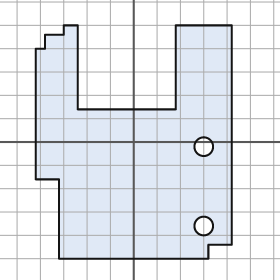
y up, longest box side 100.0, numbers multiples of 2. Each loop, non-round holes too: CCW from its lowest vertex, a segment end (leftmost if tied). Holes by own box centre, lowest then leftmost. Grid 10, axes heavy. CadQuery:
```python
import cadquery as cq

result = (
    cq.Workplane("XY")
    .moveTo(-32.0, -50.0)
    .lineTo(32.0, -50.0)
    .lineTo(32.0, -44.0)
    .lineTo(42.0, -44.0)
    .lineTo(42.0, 50.0)
    .lineTo(18.0, 50.0)
    .lineTo(18.0, 14.0)
    .lineTo(-24.0, 14.0)
    .lineTo(-24.0, 50.0)
    .lineTo(-30.0, 50.0)
    .lineTo(-30.0, 46.0)
    .lineTo(-38.0, 46.0)
    .lineTo(-38.0, 40.0)
    .lineTo(-42.0, 40.0)
    .lineTo(-42.0, -16.0)
    .lineTo(-32.0, -16.0)
    .close()
    .moveTo(30.0, -36.0)
    .circle(4.0)
    .moveTo(30.0, -2.0)
    .circle(4.0)
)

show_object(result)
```